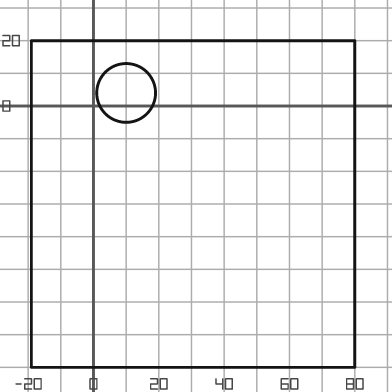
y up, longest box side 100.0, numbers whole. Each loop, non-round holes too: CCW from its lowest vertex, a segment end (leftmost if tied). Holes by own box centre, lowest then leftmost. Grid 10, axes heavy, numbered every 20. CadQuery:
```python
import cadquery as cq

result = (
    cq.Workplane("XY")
    .moveTo(-19.0, -80.0)
    .lineTo(80.0, -80.0)
    .lineTo(80.0, 20.0)
    .lineTo(-19.0, 20.0)
    .close()
    .moveTo(10.0, 4.0)
    .circle(9.0)
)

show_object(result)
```